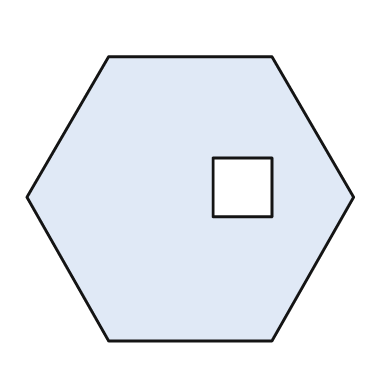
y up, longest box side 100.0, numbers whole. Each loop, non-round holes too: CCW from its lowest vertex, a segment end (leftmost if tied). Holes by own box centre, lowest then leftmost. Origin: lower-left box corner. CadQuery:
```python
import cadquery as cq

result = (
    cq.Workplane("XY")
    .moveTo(25.0, 0.0)
    .lineTo(75.0, 0.0)
    .lineTo(100.0, 44.0)
    .lineTo(75.0, 87.0)
    .lineTo(25.0, 87.0)
    .lineTo(0.0, 44.0)
    .close()
    .moveTo(57.0, 38.0)
    .lineTo(75.0, 38.0)
    .lineTo(75.0, 56.0)
    .lineTo(57.0, 56.0)
    .close()
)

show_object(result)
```